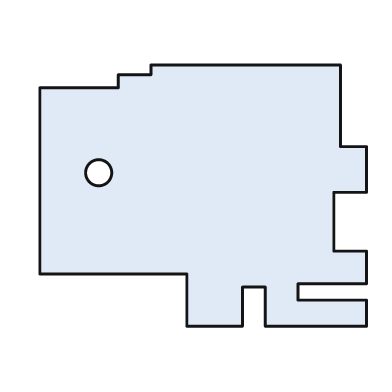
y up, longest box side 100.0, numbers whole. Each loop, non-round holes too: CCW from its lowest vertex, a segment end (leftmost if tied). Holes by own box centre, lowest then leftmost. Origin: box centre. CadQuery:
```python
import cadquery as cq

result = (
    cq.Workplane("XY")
    .moveTo(-5.0, -40.0)
    .lineTo(12.0, -40.0)
    .lineTo(12.0, -28.0)
    .lineTo(19.0, -28.0)
    .lineTo(19.0, -40.0)
    .lineTo(50.0, -40.0)
    .lineTo(50.0, -32.0)
    .lineTo(29.0, -32.0)
    .lineTo(29.0, -27.0)
    .lineTo(50.0, -27.0)
    .lineTo(50.0, -17.0)
    .lineTo(40.0, -17.0)
    .lineTo(40.0, 1.0)
    .lineTo(50.0, 1.0)
    .lineTo(50.0, 15.0)
    .lineTo(42.0, 15.0)
    .lineTo(42.0, 40.0)
    .lineTo(-16.0, 40.0)
    .lineTo(-16.0, 37.0)
    .lineTo(-26.0, 37.0)
    .lineTo(-26.0, 33.0)
    .lineTo(-50.0, 33.0)
    .lineTo(-50.0, -24.0)
    .lineTo(-5.0, -24.0)
    .close()
    .moveTo(-32.0, 7.0)
    .circle(4.0)
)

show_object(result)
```